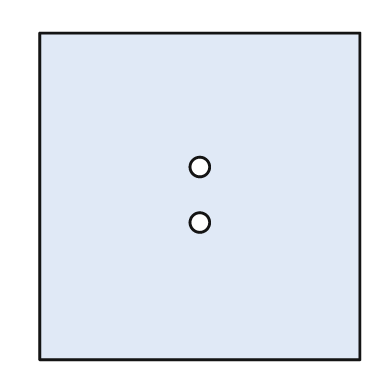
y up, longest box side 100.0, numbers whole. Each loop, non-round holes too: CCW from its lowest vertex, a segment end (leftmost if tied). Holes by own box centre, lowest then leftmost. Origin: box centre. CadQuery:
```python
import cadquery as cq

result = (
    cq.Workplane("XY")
    .moveTo(-49.0, -50.0)
    .lineTo(49.0, -50.0)
    .lineTo(49.0, 50.0)
    .lineTo(-49.0, 50.0)
    .close()
    .moveTo(0.0, -8.0)
    .circle(3.0)
    .moveTo(0.0, 9.0)
    .circle(3.0)
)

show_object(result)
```